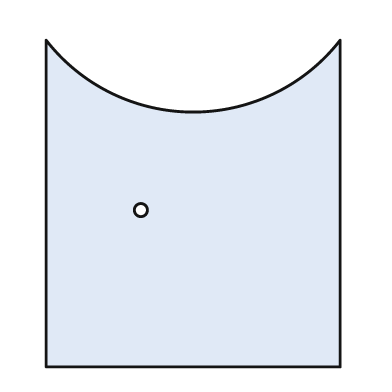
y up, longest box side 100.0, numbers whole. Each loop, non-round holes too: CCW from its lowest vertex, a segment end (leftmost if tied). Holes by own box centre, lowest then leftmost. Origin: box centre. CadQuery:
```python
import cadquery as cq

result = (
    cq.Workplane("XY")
    .moveTo(-45.0, -50.0)
    .lineTo(45.0, -50.0)
    .lineTo(45.0, 50.0)
    .threePointArc((0.0, 28.0), (-45.0, 50.0))
    .close()
    .moveTo(-16.0, -2.0)
    .circle(2.0)
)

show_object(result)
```